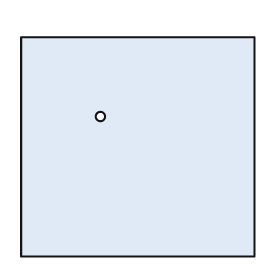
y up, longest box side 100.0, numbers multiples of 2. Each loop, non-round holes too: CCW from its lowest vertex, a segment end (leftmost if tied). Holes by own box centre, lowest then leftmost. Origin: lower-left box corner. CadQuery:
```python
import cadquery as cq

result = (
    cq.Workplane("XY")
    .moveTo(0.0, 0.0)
    .lineTo(100.0, 0.0)
    .lineTo(100.0, 94.0)
    .lineTo(0.0, 94.0)
    .close()
    .moveTo(34.0, 60.0)
    .circle(2.0)
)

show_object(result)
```